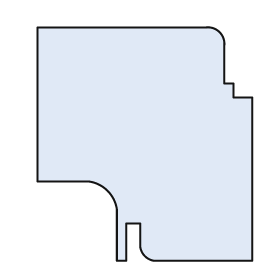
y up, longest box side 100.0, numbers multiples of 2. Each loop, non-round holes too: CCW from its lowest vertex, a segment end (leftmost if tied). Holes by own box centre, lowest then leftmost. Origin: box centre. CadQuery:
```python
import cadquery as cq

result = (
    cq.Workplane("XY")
    .moveTo(-12.0, -50.0)
    .lineTo(-8.0, -50.0)
    .lineTo(-8.0, -34.0)
    .lineTo(-2.0, -34.0)
    .lineTo(-2.0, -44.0)
    .threePointArc((0.0, -48.0), (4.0, -50.0))
    .lineTo(46.0, -50.0)
    .lineTo(46.0, 20.0)
    .lineTo(38.0, 20.0)
    .lineTo(38.0, 26.0)
    .lineTo(34.0, 26.0)
    .lineTo(34.0, 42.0)
    .threePointArc((32.0, 48.0), (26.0, 50.0))
    .lineTo(-46.0, 50.0)
    .lineTo(-46.0, -16.0)
    .lineTo(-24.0, -16.0)
    .threePointArc((-16.0, -20.0), (-12.0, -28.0))
    .close()
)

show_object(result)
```